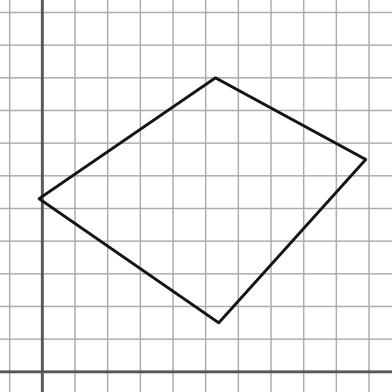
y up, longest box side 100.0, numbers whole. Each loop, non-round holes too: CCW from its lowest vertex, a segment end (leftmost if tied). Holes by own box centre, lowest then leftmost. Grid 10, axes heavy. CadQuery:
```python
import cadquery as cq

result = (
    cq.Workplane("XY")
    .moveTo(54.0, 15.0)
    .lineTo(99.0, 65.0)
    .lineTo(53.0, 90.0)
    .lineTo(-1.0, 53.0)
    .close()
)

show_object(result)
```